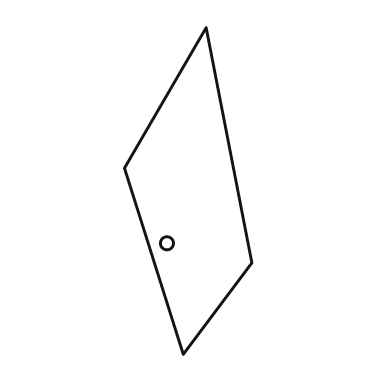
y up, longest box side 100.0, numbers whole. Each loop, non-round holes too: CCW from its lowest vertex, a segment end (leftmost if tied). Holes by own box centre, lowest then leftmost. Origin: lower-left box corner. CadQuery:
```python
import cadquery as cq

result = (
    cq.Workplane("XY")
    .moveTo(18.0, 0.0)
    .lineTo(39.0, 28.0)
    .lineTo(25.0, 100.0)
    .lineTo(0.0, 57.0)
    .close()
    .moveTo(13.0, 34.0)
    .circle(2.0)
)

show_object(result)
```